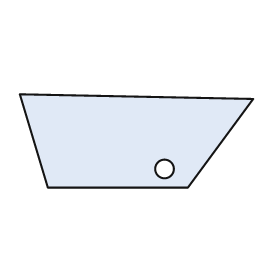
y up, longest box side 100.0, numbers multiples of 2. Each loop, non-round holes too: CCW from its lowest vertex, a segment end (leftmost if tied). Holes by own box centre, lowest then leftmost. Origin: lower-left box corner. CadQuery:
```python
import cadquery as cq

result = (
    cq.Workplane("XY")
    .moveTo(12.0, 0.0)
    .lineTo(72.0, 0.0)
    .lineTo(100.0, 38.0)
    .lineTo(0.0, 40.0)
    .close()
    .moveTo(62.0, 8.0)
    .circle(4.0)
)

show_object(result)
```